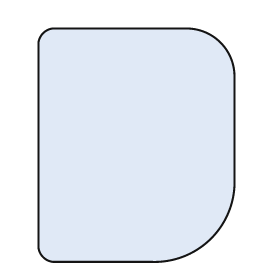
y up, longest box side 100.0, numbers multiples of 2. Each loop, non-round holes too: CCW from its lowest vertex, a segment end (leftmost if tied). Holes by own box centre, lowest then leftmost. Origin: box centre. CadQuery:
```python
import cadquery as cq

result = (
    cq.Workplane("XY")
    .moveTo(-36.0, -50.0)
    .lineTo(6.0, -50.0)
    .threePointArc((32.0, -40.0), (42.0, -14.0))
    .lineTo(42.0, 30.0)
    .threePointArc((36.0, 44.0), (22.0, 50.0))
    .lineTo(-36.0, 50.0)
    .threePointArc((-40.0, 48.0), (-42.0, 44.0))
    .lineTo(-42.0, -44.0)
    .threePointArc((-40.0, -48.0), (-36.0, -50.0))
    .close()
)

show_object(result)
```